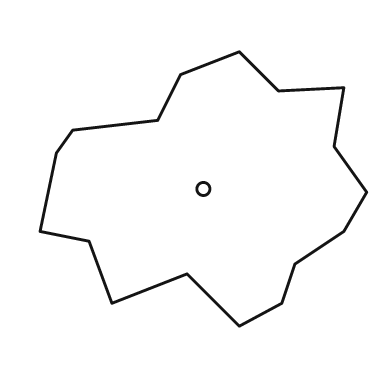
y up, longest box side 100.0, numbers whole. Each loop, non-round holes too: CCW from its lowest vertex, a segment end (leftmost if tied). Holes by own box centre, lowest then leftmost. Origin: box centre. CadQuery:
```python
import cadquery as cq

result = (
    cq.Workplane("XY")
    .moveTo(11.0, -42.0)
    .lineTo(24.0, -35.0)
    .lineTo(28.0, -23.0)
    .lineTo(43.0, -13.0)
    .lineTo(50.0, -1.0)
    .lineTo(40.0, 13.0)
    .lineTo(43.0, 31.0)
    .lineTo(23.0, 30.0)
    .lineTo(11.0, 42.0)
    .lineTo(-7.0, 35.0)
    .lineTo(-14.0, 21.0)
    .lineTo(-40.0, 18.0)
    .lineTo(-45.0, 11.0)
    .lineTo(-50.0, -13.0)
    .lineTo(-35.0, -16.0)
    .lineTo(-28.0, -35.0)
    .lineTo(-5.0, -26.0)
    .close()
    .moveTo(0.0, 0.0)
    .circle(2.0)
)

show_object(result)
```